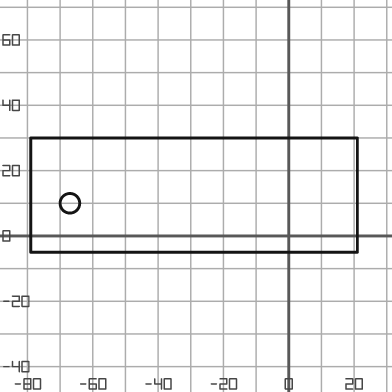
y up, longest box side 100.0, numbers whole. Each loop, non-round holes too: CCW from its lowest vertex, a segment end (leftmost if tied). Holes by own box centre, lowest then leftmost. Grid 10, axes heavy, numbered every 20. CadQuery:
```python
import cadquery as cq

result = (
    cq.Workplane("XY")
    .moveTo(-79.0, -5.0)
    .lineTo(21.0, -5.0)
    .lineTo(21.0, 30.0)
    .lineTo(-79.0, 30.0)
    .close()
    .moveTo(-67.0, 10.0)
    .circle(3.0)
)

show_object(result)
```